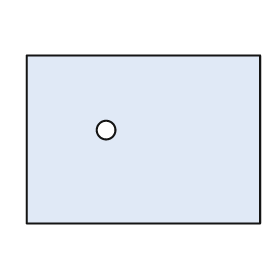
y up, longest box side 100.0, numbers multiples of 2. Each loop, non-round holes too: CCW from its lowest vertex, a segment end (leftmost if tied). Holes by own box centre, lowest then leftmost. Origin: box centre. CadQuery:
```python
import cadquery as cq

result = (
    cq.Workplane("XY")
    .moveTo(-50.0, -36.0)
    .lineTo(50.0, -36.0)
    .lineTo(50.0, 36.0)
    .lineTo(-50.0, 36.0)
    .close()
    .moveTo(-16.0, 4.0)
    .circle(4.0)
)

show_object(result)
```